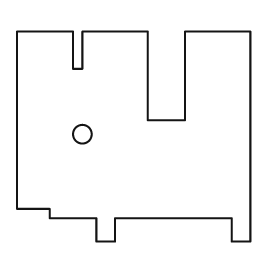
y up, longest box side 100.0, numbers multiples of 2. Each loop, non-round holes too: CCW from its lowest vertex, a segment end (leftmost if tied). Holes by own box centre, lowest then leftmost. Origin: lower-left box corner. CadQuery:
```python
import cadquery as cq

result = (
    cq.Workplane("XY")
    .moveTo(34.0, 0.0)
    .lineTo(42.0, 0.0)
    .lineTo(42.0, 10.0)
    .lineTo(92.0, 10.0)
    .lineTo(92.0, 0.0)
    .lineTo(100.0, 0.0)
    .lineTo(100.0, 90.0)
    .lineTo(72.0, 90.0)
    .lineTo(72.0, 52.0)
    .lineTo(56.0, 52.0)
    .lineTo(56.0, 90.0)
    .lineTo(28.0, 90.0)
    .lineTo(28.0, 74.0)
    .lineTo(24.0, 74.0)
    .lineTo(24.0, 90.0)
    .lineTo(0.0, 90.0)
    .lineTo(0.0, 14.0)
    .lineTo(14.0, 14.0)
    .lineTo(14.0, 10.0)
    .lineTo(34.0, 10.0)
    .close()
    .moveTo(28.0, 46.0)
    .circle(4.0)
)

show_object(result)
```